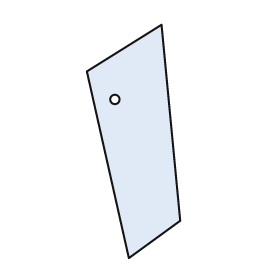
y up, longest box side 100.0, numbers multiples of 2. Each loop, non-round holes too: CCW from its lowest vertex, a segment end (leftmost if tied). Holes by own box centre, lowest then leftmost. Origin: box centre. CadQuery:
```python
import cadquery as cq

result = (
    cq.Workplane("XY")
    .moveTo(-2.0, -50.0)
    .lineTo(20.0, -34.0)
    .lineTo(12.0, 50.0)
    .lineTo(-20.0, 30.0)
    .close()
    .moveTo(-8.0, 18.0)
    .circle(2.0)
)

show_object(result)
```